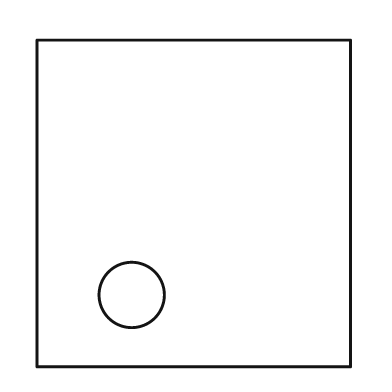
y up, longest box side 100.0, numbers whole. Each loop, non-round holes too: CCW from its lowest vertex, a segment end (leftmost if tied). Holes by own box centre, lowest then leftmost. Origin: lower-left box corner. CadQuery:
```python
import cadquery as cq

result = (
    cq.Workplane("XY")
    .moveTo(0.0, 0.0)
    .lineTo(96.0, 0.0)
    .lineTo(96.0, 100.0)
    .lineTo(0.0, 100.0)
    .close()
    .moveTo(29.0, 22.0)
    .circle(10.0)
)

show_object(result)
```